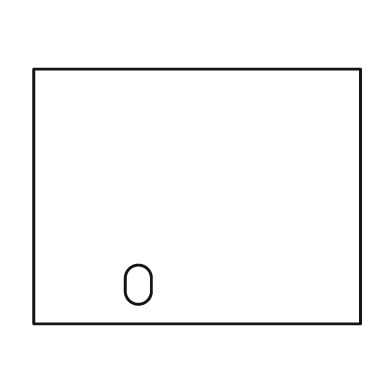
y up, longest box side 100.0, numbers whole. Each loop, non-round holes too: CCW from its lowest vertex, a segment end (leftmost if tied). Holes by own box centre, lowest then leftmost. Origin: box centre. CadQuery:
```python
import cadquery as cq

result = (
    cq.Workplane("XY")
    .moveTo(-50.0, -39.0)
    .lineTo(50.0, -39.0)
    .lineTo(50.0, 39.0)
    .lineTo(-50.0, 39.0)
    .close()
    .moveTo(-22.0, -29.0)
    .threePointArc((-18.0, -33.0), (-14.0, -29.0))
    .lineTo(-14.0, -25.0)
    .threePointArc((-18.0, -21.0), (-22.0, -25.0))
    .close()
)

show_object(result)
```